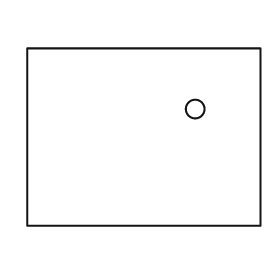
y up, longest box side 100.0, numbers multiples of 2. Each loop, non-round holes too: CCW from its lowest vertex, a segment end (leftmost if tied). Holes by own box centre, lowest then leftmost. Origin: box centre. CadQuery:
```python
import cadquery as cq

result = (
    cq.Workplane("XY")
    .moveTo(-50.0, -38.0)
    .lineTo(50.0, -38.0)
    .lineTo(50.0, 38.0)
    .lineTo(-50.0, 38.0)
    .close()
    .moveTo(22.0, 12.0)
    .circle(4.0)
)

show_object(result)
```